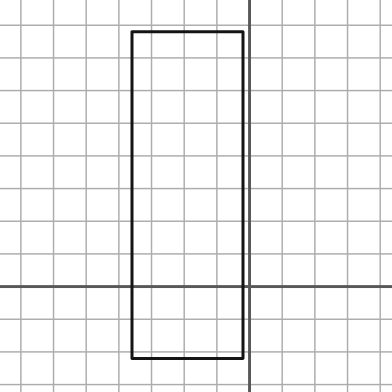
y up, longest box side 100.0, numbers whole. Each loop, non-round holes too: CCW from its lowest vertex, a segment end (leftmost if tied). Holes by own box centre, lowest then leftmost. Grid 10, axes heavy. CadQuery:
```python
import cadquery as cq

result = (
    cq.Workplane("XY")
    .moveTo(-36.0, -22.0)
    .lineTo(-2.0, -22.0)
    .lineTo(-2.0, 78.0)
    .lineTo(-36.0, 78.0)
    .close()
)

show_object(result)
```